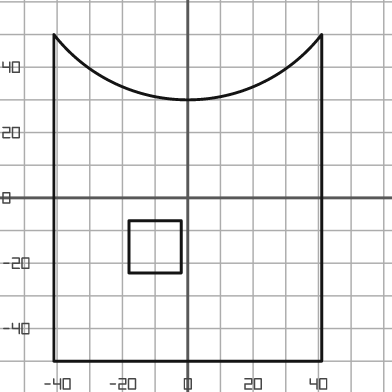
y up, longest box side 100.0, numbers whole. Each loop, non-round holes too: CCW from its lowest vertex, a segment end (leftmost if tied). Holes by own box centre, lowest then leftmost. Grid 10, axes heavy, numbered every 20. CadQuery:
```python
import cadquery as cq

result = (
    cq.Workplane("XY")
    .moveTo(-41.0, -50.0)
    .lineTo(41.0, -50.0)
    .lineTo(41.0, 50.0)
    .threePointArc((0.0, 30.0), (-41.0, 50.0))
    .close()
    .moveTo(-18.0, -23.0)
    .lineTo(-2.0, -23.0)
    .lineTo(-2.0, -7.0)
    .lineTo(-18.0, -7.0)
    .close()
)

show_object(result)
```